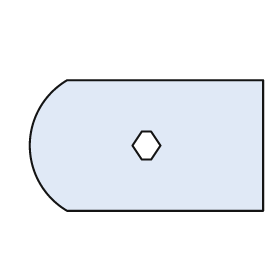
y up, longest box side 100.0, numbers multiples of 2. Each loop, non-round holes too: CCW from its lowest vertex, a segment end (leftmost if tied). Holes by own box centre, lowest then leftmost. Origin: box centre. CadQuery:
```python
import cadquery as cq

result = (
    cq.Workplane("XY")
    .moveTo(-34.0, -28.0)
    .lineTo(50.0, -28.0)
    .lineTo(50.0, 28.0)
    .lineTo(-34.0, 28.0)
    .threePointArc((-50.0, 0.0), (-34.0, -28.0))
    .close()
    .moveTo(-2.0, -6.0)
    .lineTo(2.0, -6.0)
    .lineTo(6.0, 0.0)
    .lineTo(2.0, 6.0)
    .lineTo(-2.0, 6.0)
    .lineTo(-6.0, 0.0)
    .close()
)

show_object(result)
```